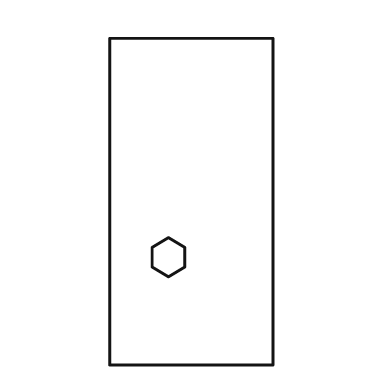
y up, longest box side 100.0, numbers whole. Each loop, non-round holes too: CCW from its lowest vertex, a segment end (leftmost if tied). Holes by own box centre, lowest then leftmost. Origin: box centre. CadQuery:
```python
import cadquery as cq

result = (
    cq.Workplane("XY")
    .moveTo(-25.0, -50.0)
    .lineTo(25.0, -50.0)
    .lineTo(25.0, 50.0)
    .lineTo(-25.0, 50.0)
    .close()
    .moveTo(-7.0, -23.0)
    .lineTo(-2.0, -20.0)
    .lineTo(-2.0, -14.0)
    .lineTo(-7.0, -11.0)
    .lineTo(-12.0, -14.0)
    .lineTo(-12.0, -20.0)
    .close()
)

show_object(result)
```